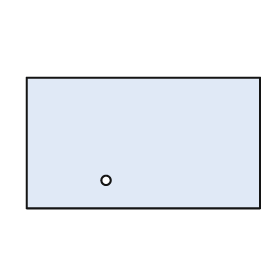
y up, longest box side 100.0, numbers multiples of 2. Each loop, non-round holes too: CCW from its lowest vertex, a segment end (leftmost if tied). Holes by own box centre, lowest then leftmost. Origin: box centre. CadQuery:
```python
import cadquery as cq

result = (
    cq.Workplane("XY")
    .moveTo(-50.0, -28.0)
    .lineTo(50.0, -28.0)
    .lineTo(50.0, 28.0)
    .lineTo(-50.0, 28.0)
    .close()
    .moveTo(-16.0, -16.0)
    .circle(2.0)
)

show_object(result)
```